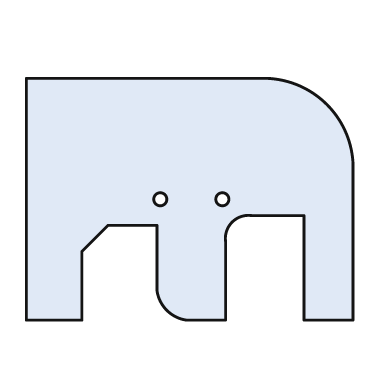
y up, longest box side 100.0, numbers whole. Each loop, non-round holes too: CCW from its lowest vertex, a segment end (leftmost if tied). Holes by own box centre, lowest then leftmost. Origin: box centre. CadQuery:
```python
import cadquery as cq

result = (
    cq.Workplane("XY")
    .moveTo(-50.0, -37.0)
    .lineTo(-33.0, -37.0)
    .lineTo(-33.0, -16.0)
    .lineTo(-25.0, -8.0)
    .lineTo(-10.0, -8.0)
    .lineTo(-10.0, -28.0)
    .threePointArc((-7.0, -34.0), (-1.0, -37.0))
    .lineTo(11.0, -37.0)
    .lineTo(11.0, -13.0)
    .threePointArc((13.0, -7.0), (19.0, -5.0))
    .lineTo(35.0, -5.0)
    .lineTo(35.0, -37.0)
    .lineTo(50.0, -37.0)
    .lineTo(50.0, 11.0)
    .threePointArc((42.0, 29.0), (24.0, 37.0))
    .lineTo(-50.0, 37.0)
    .close()
    .moveTo(-9.0, 0.0)
    .circle(2.0)
    .moveTo(10.0, 0.0)
    .circle(2.0)
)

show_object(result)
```